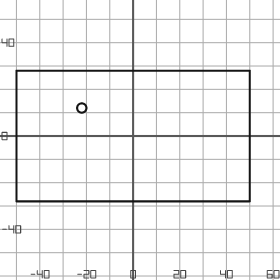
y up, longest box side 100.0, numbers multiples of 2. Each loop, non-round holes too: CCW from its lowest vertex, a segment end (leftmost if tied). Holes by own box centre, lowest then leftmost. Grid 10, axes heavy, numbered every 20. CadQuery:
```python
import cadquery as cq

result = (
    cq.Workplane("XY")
    .moveTo(-50.0, -28.0)
    .lineTo(50.0, -28.0)
    .lineTo(50.0, 28.0)
    .lineTo(-50.0, 28.0)
    .close()
    .moveTo(-22.0, 12.0)
    .circle(2.0)
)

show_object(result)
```